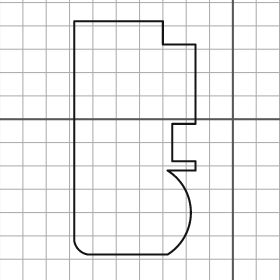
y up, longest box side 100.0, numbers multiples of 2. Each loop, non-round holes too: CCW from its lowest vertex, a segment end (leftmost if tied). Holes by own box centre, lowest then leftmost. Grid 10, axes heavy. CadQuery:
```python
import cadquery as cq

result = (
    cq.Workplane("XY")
    .moveTo(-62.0, -58.0)
    .lineTo(-28.0, -58.0)
    .threePointArc((-18.0, -40.0), (-28.0, -22.0))
    .lineTo(-16.0, -22.0)
    .lineTo(-16.0, -18.0)
    .lineTo(-26.0, -18.0)
    .lineTo(-26.0, -2.0)
    .lineTo(-16.0, -2.0)
    .lineTo(-16.0, 32.0)
    .lineTo(-30.0, 32.0)
    .lineTo(-30.0, 42.0)
    .lineTo(-68.0, 42.0)
    .lineTo(-68.0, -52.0)
    .threePointArc((-66.0, -56.0), (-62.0, -58.0))
    .close()
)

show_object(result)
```